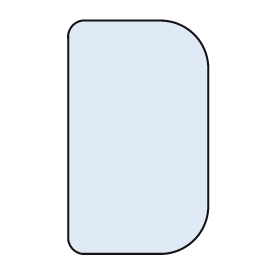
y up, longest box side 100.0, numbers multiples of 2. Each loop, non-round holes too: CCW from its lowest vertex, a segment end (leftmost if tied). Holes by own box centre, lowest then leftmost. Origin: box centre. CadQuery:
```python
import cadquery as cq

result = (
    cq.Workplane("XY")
    .moveTo(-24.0, -50.0)
    .lineTo(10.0, -50.0)
    .threePointArc((24.0, -44.0), (30.0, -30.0))
    .lineTo(30.0, 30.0)
    .threePointArc((24.0, 44.0), (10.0, 50.0))
    .lineTo(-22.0, 50.0)
    .threePointArc((-28.0, 48.0), (-30.0, 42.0))
    .lineTo(-30.0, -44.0)
    .threePointArc((-28.0, -48.0), (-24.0, -50.0))
    .close()
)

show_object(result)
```